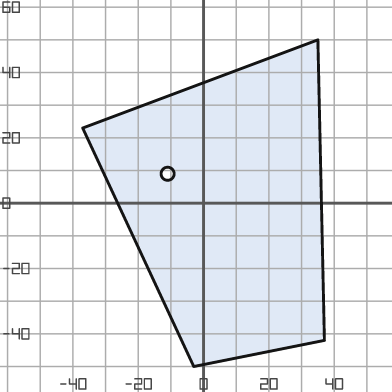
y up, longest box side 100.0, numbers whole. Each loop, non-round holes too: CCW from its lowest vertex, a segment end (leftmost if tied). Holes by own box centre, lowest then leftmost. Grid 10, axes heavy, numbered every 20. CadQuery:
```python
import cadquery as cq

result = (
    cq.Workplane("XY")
    .moveTo(-3.0, -50.0)
    .lineTo(37.0, -42.0)
    .lineTo(35.0, 50.0)
    .lineTo(-37.0, 23.0)
    .close()
    .moveTo(-11.0, 9.0)
    .circle(2.0)
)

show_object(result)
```